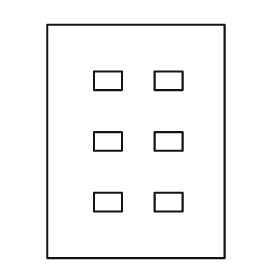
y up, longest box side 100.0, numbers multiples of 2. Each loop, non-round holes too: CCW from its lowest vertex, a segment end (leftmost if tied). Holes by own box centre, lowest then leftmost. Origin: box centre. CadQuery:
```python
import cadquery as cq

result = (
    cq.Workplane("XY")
    .moveTo(-38.0, -50.0)
    .lineTo(38.0, -50.0)
    .lineTo(38.0, 50.0)
    .lineTo(-38.0, 50.0)
    .close()
    .moveTo(-18.0, -30.0)
    .lineTo(-6.0, -30.0)
    .lineTo(-6.0, -22.0)
    .lineTo(-18.0, -22.0)
    .close()
    .moveTo(8.0, -30.0)
    .lineTo(20.0, -30.0)
    .lineTo(20.0, -22.0)
    .lineTo(8.0, -22.0)
    .close()
    .moveTo(-18.0, -4.0)
    .lineTo(-6.0, -4.0)
    .lineTo(-6.0, 4.0)
    .lineTo(-18.0, 4.0)
    .close()
    .moveTo(8.0, -4.0)
    .lineTo(20.0, -4.0)
    .lineTo(20.0, 4.0)
    .lineTo(8.0, 4.0)
    .close()
    .moveTo(-18.0, 22.0)
    .lineTo(-6.0, 22.0)
    .lineTo(-6.0, 30.0)
    .lineTo(-18.0, 30.0)
    .close()
    .moveTo(8.0, 22.0)
    .lineTo(20.0, 22.0)
    .lineTo(20.0, 30.0)
    .lineTo(8.0, 30.0)
    .close()
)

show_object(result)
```